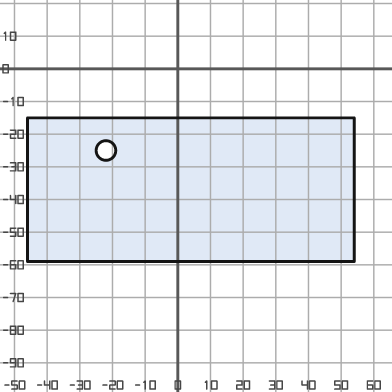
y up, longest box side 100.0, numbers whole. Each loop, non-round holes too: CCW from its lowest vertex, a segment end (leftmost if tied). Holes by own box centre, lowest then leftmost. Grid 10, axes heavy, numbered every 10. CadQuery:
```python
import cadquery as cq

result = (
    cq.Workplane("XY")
    .moveTo(-46.0, -59.0)
    .lineTo(54.0, -59.0)
    .lineTo(54.0, -15.0)
    .lineTo(-46.0, -15.0)
    .close()
    .moveTo(-22.0, -25.0)
    .circle(3.0)
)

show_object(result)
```